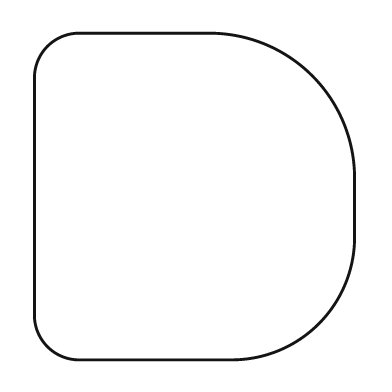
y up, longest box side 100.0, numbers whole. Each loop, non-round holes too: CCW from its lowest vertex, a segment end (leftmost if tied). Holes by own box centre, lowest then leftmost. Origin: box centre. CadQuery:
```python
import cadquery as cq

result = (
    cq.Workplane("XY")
    .moveTo(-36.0, -50.0)
    .lineTo(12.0, -50.0)
    .threePointArc((38.0, -39.0), (49.0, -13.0))
    .lineTo(49.0, 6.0)
    .threePointArc((36.0, 37.0), (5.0, 50.0))
    .lineTo(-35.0, 50.0)
    .threePointArc((-45.0, 46.0), (-49.0, 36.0))
    .lineTo(-49.0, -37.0)
    .threePointArc((-45.0, -46.0), (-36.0, -50.0))
    .close()
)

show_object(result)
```